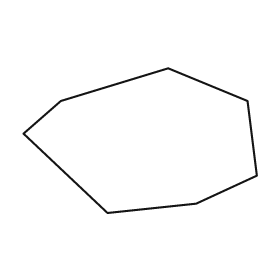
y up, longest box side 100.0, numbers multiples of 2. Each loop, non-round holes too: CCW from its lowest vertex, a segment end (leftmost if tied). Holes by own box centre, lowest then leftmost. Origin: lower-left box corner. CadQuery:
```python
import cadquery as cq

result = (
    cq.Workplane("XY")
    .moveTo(36.0, 0.0)
    .lineTo(74.0, 4.0)
    .lineTo(100.0, 16.0)
    .lineTo(96.0, 48.0)
    .lineTo(62.0, 62.0)
    .lineTo(16.0, 48.0)
    .lineTo(0.0, 34.0)
    .close()
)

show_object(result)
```